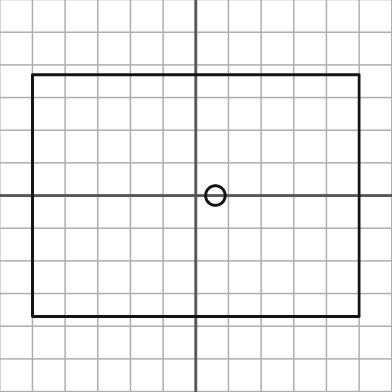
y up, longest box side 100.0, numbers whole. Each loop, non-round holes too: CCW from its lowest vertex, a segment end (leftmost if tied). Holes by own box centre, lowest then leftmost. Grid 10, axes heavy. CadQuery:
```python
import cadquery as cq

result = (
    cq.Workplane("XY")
    .moveTo(-50.0, -37.0)
    .lineTo(50.0, -37.0)
    .lineTo(50.0, 37.0)
    .lineTo(-50.0, 37.0)
    .close()
    .moveTo(6.0, 0.0)
    .circle(3.0)
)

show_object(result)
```